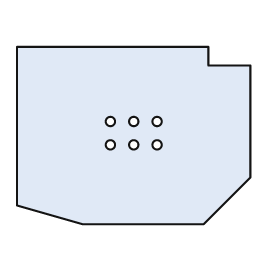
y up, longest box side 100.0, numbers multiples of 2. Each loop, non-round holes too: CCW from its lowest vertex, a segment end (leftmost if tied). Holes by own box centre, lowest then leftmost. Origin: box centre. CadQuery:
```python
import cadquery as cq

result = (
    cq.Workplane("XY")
    .moveTo(-22.0, -38.0)
    .lineTo(30.0, -38.0)
    .lineTo(50.0, -18.0)
    .lineTo(50.0, 30.0)
    .lineTo(32.0, 30.0)
    .lineTo(32.0, 38.0)
    .lineTo(-50.0, 38.0)
    .lineTo(-50.0, -30.0)
    .close()
    .moveTo(-10.0, -4.0)
    .circle(2.0)
    .moveTo(0.0, -4.0)
    .circle(2.0)
    .moveTo(10.0, -4.0)
    .circle(2.0)
    .moveTo(-10.0, 6.0)
    .circle(2.0)
    .moveTo(0.0, 6.0)
    .circle(2.0)
    .moveTo(10.0, 6.0)
    .circle(2.0)
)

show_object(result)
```